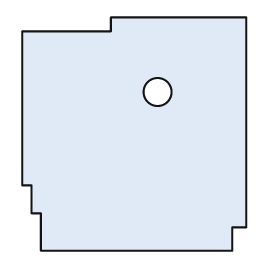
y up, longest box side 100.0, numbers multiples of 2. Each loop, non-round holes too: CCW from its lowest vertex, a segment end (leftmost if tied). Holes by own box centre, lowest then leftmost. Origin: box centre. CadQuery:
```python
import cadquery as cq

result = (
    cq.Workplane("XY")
    .moveTo(-40.0, -50.0)
    .lineTo(42.0, -50.0)
    .lineTo(42.0, -40.0)
    .lineTo(48.0, -40.0)
    .lineTo(48.0, 50.0)
    .lineTo(-10.0, 50.0)
    .lineTo(-10.0, 44.0)
    .lineTo(-48.0, 44.0)
    .lineTo(-48.0, -22.0)
    .lineTo(-44.0, -22.0)
    .lineTo(-44.0, -34.0)
    .lineTo(-40.0, -34.0)
    .close()
    .moveTo(10.0, 18.0)
    .circle(6.0)
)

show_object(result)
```